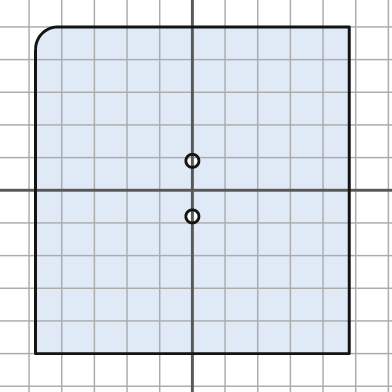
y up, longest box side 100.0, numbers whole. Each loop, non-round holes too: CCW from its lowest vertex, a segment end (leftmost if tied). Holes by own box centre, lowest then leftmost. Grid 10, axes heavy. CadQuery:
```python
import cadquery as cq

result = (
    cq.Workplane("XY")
    .moveTo(-48.0, -50.0)
    .lineTo(48.0, -50.0)
    .lineTo(48.0, 50.0)
    .lineTo(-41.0, 50.0)
    .threePointArc((-46.0, 48.0), (-48.0, 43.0))
    .close()
    .moveTo(0.0, -8.0)
    .circle(2.0)
    .moveTo(0.0, 9.0)
    .circle(2.0)
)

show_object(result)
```